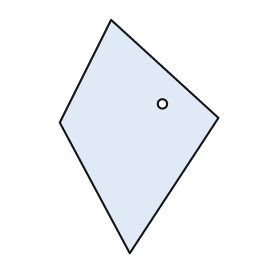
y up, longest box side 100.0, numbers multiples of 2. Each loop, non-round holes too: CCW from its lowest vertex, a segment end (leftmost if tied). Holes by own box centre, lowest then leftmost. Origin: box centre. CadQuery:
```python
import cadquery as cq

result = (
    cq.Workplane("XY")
    .moveTo(-4.0, -50.0)
    .lineTo(34.0, 8.0)
    .lineTo(-12.0, 50.0)
    .lineTo(-34.0, 6.0)
    .close()
    .moveTo(10.0, 14.0)
    .circle(2.0)
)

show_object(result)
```